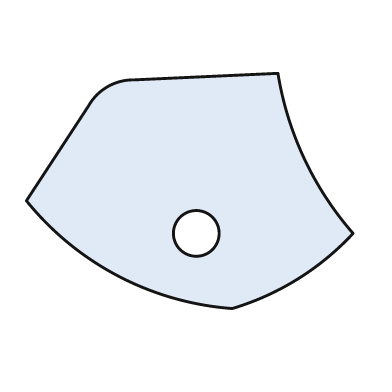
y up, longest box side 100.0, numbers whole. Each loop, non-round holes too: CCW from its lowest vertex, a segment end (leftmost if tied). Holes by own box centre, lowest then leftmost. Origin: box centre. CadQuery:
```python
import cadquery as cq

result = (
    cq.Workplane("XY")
    .moveTo(13.0, -36.0)
    .threePointArc((33.0, -27.0), (50.0, -13.0))
    .threePointArc((35.0, 10.0), (27.0, 36.0))
    .lineTo(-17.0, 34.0)
    .threePointArc((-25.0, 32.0), (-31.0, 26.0))
    .lineTo(-50.0, -3.0)
    .threePointArc((-22.0, -26.0), (13.0, -36.0))
    .close()
    .moveTo(2.0, -13.0)
    .circle(7.0)
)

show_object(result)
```